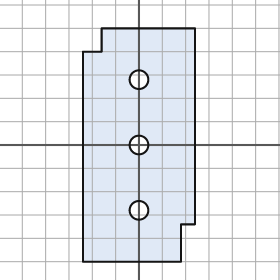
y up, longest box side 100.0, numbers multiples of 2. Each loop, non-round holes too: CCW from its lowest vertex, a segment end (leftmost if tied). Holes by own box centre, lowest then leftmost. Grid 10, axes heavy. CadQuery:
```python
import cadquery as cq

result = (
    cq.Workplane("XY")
    .moveTo(-24.0, -50.0)
    .lineTo(18.0, -50.0)
    .lineTo(18.0, -34.0)
    .lineTo(24.0, -34.0)
    .lineTo(24.0, 50.0)
    .lineTo(-16.0, 50.0)
    .lineTo(-16.0, 40.0)
    .lineTo(-24.0, 40.0)
    .close()
    .moveTo(0.0, -28.0)
    .circle(4.0)
    .moveTo(0.0, 0.0)
    .circle(4.0)
    .moveTo(0.0, 28.0)
    .circle(4.0)
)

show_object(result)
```